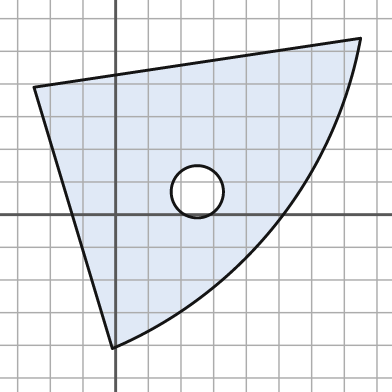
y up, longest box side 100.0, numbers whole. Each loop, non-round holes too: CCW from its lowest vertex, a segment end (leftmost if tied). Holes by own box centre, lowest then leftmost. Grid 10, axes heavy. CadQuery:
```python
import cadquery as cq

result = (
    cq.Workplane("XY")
    .moveTo(-1.0, -41.0)
    .threePointArc((49.0, -3.0), (75.0, 54.0))
    .lineTo(-25.0, 39.0)
    .close()
    .moveTo(25.0, 7.0)
    .circle(8.0)
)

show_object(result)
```